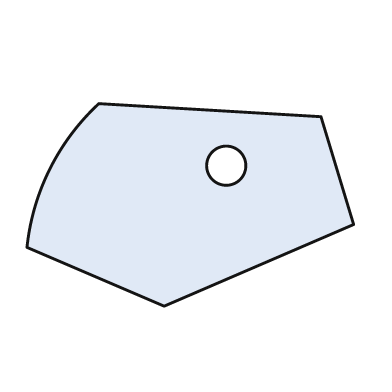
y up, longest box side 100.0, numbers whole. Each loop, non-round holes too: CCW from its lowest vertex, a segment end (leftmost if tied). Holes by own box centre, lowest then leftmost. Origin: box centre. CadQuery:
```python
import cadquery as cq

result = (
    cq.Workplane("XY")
    .moveTo(-8.0, -31.0)
    .lineTo(50.0, -6.0)
    .lineTo(40.0, 27.0)
    .lineTo(-28.0, 31.0)
    .threePointArc((-43.0, 11.0), (-50.0, -13.0))
    .close()
    .moveTo(11.0, 12.0)
    .circle(6.0)
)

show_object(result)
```